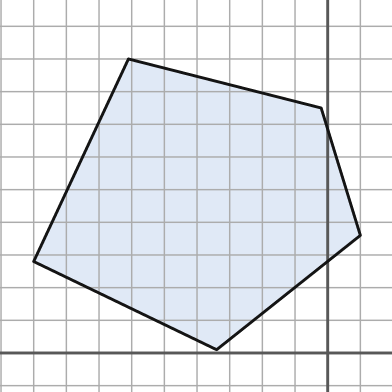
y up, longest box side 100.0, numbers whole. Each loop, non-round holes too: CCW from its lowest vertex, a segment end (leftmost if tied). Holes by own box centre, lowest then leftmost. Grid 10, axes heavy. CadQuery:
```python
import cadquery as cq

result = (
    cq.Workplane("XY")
    .moveTo(-34.0, 1.0)
    .lineTo(10.0, 36.0)
    .lineTo(-2.0, 75.0)
    .lineTo(-61.0, 90.0)
    .lineTo(-90.0, 28.0)
    .close()
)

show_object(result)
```